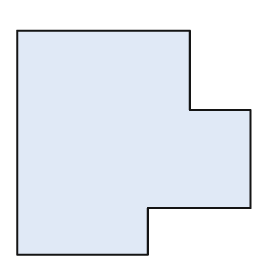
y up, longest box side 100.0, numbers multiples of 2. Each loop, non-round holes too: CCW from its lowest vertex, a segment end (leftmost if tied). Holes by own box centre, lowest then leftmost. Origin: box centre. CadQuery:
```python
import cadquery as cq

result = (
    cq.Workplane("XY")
    .moveTo(-50.0, -48.0)
    .lineTo(6.0, -48.0)
    .lineTo(6.0, -28.0)
    .lineTo(50.0, -28.0)
    .lineTo(50.0, 14.0)
    .lineTo(24.0, 14.0)
    .lineTo(24.0, 48.0)
    .lineTo(-50.0, 48.0)
    .close()
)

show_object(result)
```